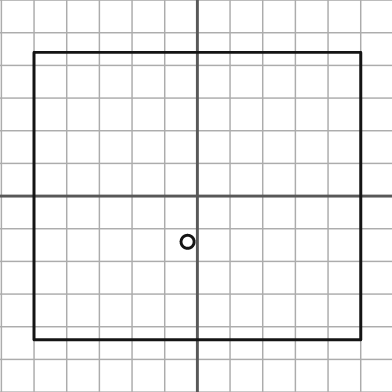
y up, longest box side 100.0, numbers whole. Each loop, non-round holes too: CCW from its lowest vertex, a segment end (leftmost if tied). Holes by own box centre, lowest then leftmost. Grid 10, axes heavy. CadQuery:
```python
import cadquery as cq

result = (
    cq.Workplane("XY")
    .moveTo(-50.0, -44.0)
    .lineTo(50.0, -44.0)
    .lineTo(50.0, 44.0)
    .lineTo(-50.0, 44.0)
    .close()
    .moveTo(-3.0, -14.0)
    .circle(2.0)
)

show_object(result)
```